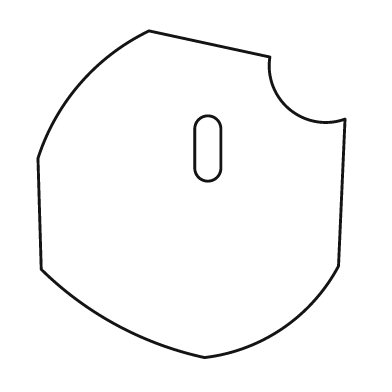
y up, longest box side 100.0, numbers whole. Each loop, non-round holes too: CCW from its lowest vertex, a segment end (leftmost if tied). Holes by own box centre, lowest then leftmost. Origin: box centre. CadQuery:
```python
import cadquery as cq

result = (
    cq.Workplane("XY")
    .moveTo(4.0, -50.0)
    .threePointArc((28.0, -41.0), (45.0, -22.0))
    .lineTo(47.0, 23.0)
    .threePointArc((30.0, 26.0), (24.0, 42.0))
    .lineTo(-13.0, 50.0)
    .threePointArc((-34.0, 34.0), (-47.0, 11.0))
    .lineTo(-46.0, -23.0)
    .threePointArc((-23.0, -40.0), (4.0, -50.0))
    .close()
    .moveTo(1.0, 8.0)
    .threePointArc((5.0, 4.0), (9.0, 8.0))
    .lineTo(9.0, 20.0)
    .threePointArc((5.0, 24.0), (1.0, 20.0))
    .close()
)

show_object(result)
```